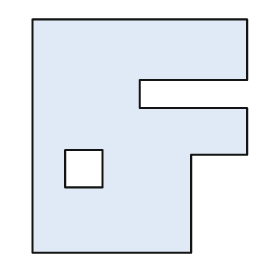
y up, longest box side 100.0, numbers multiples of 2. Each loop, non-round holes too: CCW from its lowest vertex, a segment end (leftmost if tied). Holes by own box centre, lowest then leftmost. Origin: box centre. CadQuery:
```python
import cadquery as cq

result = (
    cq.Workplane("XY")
    .moveTo(-46.0, -50.0)
    .lineTo(22.0, -50.0)
    .lineTo(22.0, -8.0)
    .lineTo(46.0, -8.0)
    .lineTo(46.0, 12.0)
    .lineTo(0.0, 12.0)
    .lineTo(0.0, 24.0)
    .lineTo(46.0, 24.0)
    .lineTo(46.0, 50.0)
    .lineTo(-46.0, 50.0)
    .close()
    .moveTo(-32.0, -22.0)
    .lineTo(-16.0, -22.0)
    .lineTo(-16.0, -6.0)
    .lineTo(-32.0, -6.0)
    .close()
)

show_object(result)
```